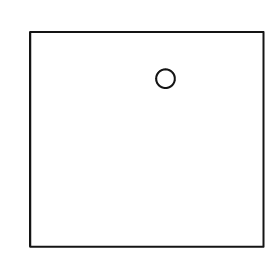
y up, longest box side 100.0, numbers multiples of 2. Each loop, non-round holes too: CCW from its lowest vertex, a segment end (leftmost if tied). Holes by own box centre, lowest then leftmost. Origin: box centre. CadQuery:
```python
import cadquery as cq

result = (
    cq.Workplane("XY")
    .moveTo(-50.0, -46.0)
    .lineTo(50.0, -46.0)
    .lineTo(50.0, 46.0)
    .lineTo(-50.0, 46.0)
    .close()
    .moveTo(8.0, 26.0)
    .circle(4.0)
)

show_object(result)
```